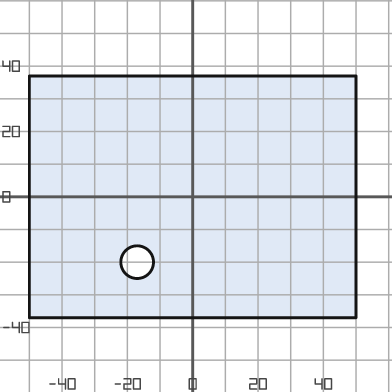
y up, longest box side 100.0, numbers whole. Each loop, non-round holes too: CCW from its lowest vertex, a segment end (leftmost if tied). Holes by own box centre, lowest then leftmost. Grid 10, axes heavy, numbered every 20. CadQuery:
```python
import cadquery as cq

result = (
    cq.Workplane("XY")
    .moveTo(-50.0, -37.0)
    .lineTo(50.0, -37.0)
    .lineTo(50.0, 37.0)
    .lineTo(-50.0, 37.0)
    .close()
    .moveTo(-17.0, -20.0)
    .circle(5.0)
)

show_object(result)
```